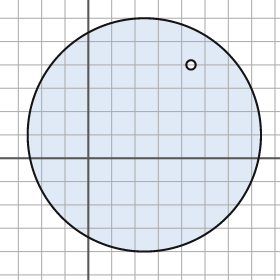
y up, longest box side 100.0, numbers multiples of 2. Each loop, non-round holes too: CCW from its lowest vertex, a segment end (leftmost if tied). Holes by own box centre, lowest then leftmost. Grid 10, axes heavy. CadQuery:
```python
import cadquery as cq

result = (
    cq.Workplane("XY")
    .moveTo(24.0, 10.0)
    .circle(50.0)
    .moveTo(44.0, 40.0)
    .circle(2.0)
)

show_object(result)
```